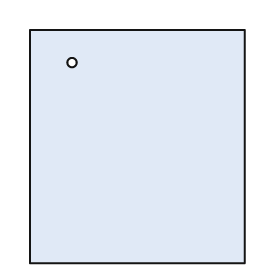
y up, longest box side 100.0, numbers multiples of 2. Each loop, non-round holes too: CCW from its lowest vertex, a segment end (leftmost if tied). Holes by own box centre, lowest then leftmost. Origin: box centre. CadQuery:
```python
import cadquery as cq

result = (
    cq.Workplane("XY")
    .moveTo(-46.0, -50.0)
    .lineTo(46.0, -50.0)
    .lineTo(46.0, 50.0)
    .lineTo(-46.0, 50.0)
    .close()
    .moveTo(-28.0, 36.0)
    .circle(2.0)
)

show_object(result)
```